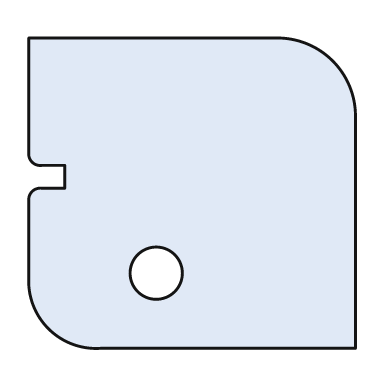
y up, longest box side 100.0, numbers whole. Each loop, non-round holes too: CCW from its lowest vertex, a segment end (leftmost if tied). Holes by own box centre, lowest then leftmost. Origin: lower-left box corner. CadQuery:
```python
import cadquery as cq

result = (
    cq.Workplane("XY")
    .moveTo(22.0, 0.0)
    .lineTo(100.0, 0.0)
    .lineTo(100.0, 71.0)
    .threePointArc((93.0, 88.0), (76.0, 95.0))
    .lineTo(0.0, 95.0)
    .lineTo(0.0, 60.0)
    .threePointArc((1.0, 57.0), (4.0, 56.0))
    .lineTo(11.0, 56.0)
    .lineTo(11.0, 49.0)
    .lineTo(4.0, 49.0)
    .threePointArc((1.0, 48.0), (0.0, 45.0))
    .lineTo(0.0, 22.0)
    .threePointArc((6.0, 6.0), (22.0, 0.0))
    .close()
    .moveTo(39.0, 23.0)
    .circle(8.0)
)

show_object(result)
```